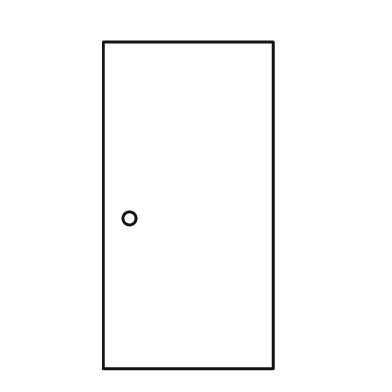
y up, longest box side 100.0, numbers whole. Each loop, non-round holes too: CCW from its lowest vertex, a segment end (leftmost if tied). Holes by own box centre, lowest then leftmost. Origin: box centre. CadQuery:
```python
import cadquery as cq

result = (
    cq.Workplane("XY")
    .moveTo(-26.0, -50.0)
    .lineTo(26.0, -50.0)
    .lineTo(26.0, 50.0)
    .lineTo(-26.0, 50.0)
    .close()
    .moveTo(-18.0, -4.0)
    .circle(2.0)
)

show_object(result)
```